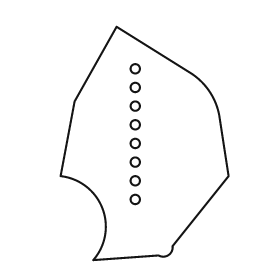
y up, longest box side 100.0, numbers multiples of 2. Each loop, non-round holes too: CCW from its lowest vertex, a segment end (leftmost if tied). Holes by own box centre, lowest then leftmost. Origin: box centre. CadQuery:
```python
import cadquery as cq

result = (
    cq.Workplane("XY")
    .moveTo(-22.0, -50.0)
    .lineTo(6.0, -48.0)
    .threePointArc((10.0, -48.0), (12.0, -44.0))
    .lineTo(36.0, -14.0)
    .lineTo(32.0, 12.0)
    .threePointArc((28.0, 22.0), (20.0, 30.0))
    .lineTo(-12.0, 50.0)
    .lineTo(-30.0, 18.0)
    .lineTo(-36.0, -14.0)
    .threePointArc((-18.0, -28.0), (-22.0, -50.0))
    .close()
    .moveTo(-4.0, -24.0)
    .circle(2.0)
    .moveTo(-4.0, -16.0)
    .circle(2.0)
    .moveTo(-4.0, -8.0)
    .circle(2.0)
    .moveTo(-4.0, 0.0)
    .circle(2.0)
    .moveTo(-4.0, 8.0)
    .circle(2.0)
    .moveTo(-4.0, 16.0)
    .circle(2.0)
    .moveTo(-4.0, 24.0)
    .circle(2.0)
    .moveTo(-4.0, 32.0)
    .circle(2.0)
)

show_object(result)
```